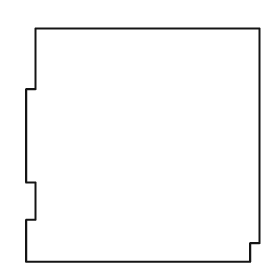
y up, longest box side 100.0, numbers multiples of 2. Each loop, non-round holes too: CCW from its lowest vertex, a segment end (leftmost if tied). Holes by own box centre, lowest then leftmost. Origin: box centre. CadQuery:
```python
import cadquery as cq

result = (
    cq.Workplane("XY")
    .moveTo(-50.0, -50.0)
    .lineTo(46.0, -50.0)
    .lineTo(46.0, -42.0)
    .lineTo(50.0, -42.0)
    .lineTo(50.0, 50.0)
    .lineTo(-46.0, 50.0)
    .lineTo(-46.0, 24.0)
    .lineTo(-50.0, 24.0)
    .lineTo(-50.0, -16.0)
    .lineTo(-46.0, -16.0)
    .lineTo(-46.0, -32.0)
    .lineTo(-50.0, -32.0)
    .close()
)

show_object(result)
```